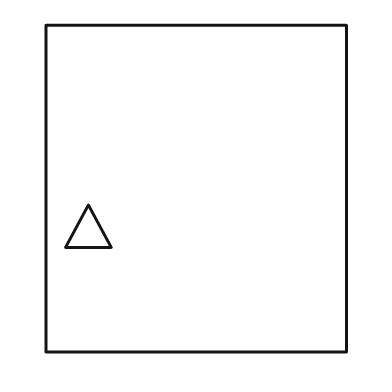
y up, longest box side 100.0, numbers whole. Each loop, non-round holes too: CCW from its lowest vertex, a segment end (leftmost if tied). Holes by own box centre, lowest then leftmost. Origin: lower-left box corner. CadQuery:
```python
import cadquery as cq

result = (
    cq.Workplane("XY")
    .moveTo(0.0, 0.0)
    .lineTo(92.0, 0.0)
    .lineTo(92.0, 100.0)
    .lineTo(0.0, 100.0)
    .close()
    .moveTo(6.0, 32.0)
    .lineTo(20.0, 32.0)
    .lineTo(13.0, 45.0)
    .close()
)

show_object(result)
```